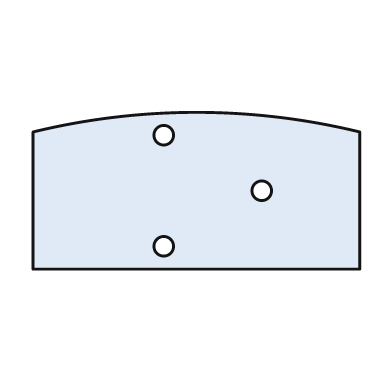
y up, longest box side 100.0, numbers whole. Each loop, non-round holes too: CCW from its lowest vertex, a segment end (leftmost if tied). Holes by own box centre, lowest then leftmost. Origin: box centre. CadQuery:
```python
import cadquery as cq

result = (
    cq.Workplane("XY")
    .moveTo(-50.0, -24.0)
    .lineTo(50.0, -24.0)
    .lineTo(50.0, 18.0)
    .threePointArc((0.0, 24.0), (-50.0, 18.0))
    .close()
    .moveTo(-10.0, -17.0)
    .circle(3.0)
    .moveTo(20.0, 0.0)
    .circle(3.0)
    .moveTo(-10.0, 17.0)
    .circle(3.0)
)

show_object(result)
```